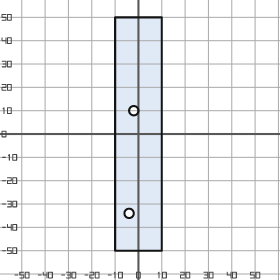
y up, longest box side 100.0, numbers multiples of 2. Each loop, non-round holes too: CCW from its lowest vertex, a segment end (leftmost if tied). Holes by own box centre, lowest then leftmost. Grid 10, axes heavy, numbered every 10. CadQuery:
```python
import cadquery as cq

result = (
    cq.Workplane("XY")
    .moveTo(-10.0, -50.0)
    .lineTo(10.0, -50.0)
    .lineTo(10.0, 50.0)
    .lineTo(-10.0, 50.0)
    .close()
    .moveTo(-4.0, -34.0)
    .circle(2.0)
    .moveTo(-2.0, 10.0)
    .circle(2.0)
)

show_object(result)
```